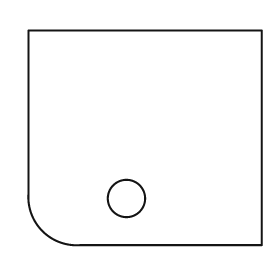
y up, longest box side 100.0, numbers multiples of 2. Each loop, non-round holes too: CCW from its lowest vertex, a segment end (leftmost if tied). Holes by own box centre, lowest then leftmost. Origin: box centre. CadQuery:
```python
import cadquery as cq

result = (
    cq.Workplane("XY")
    .moveTo(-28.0, -46.0)
    .lineTo(50.0, -46.0)
    .lineTo(50.0, 46.0)
    .lineTo(-50.0, 46.0)
    .lineTo(-50.0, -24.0)
    .threePointArc((-44.0, -40.0), (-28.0, -46.0))
    .close()
    .moveTo(-8.0, -26.0)
    .circle(8.0)
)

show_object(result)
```